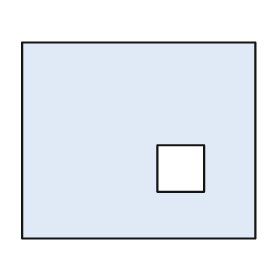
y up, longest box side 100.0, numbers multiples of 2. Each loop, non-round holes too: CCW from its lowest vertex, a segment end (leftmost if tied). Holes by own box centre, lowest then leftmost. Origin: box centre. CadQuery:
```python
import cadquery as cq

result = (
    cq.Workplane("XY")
    .moveTo(-50.0, -42.0)
    .lineTo(50.0, -42.0)
    .lineTo(50.0, 42.0)
    .lineTo(-50.0, 42.0)
    .close()
    .moveTo(8.0, -22.0)
    .lineTo(28.0, -22.0)
    .lineTo(28.0, -2.0)
    .lineTo(8.0, -2.0)
    .close()
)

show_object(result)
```